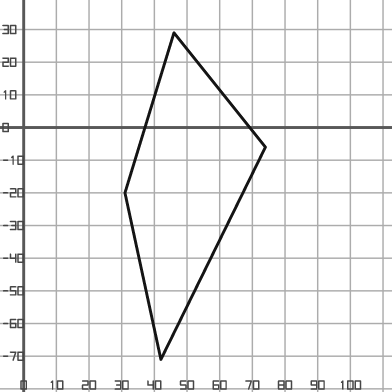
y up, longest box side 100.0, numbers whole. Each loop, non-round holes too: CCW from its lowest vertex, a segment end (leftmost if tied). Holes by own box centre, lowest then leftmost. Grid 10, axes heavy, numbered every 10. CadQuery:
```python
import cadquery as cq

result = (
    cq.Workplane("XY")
    .moveTo(42.0, -71.0)
    .lineTo(74.0, -6.0)
    .lineTo(46.0, 29.0)
    .lineTo(31.0, -20.0)
    .close()
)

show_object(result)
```